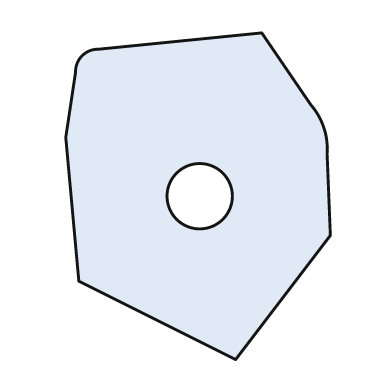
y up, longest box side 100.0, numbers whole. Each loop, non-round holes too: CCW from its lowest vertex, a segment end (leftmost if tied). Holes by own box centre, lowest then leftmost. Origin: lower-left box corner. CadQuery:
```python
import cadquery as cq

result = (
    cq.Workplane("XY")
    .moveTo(52.0, 0.0)
    .lineTo(81.0, 38.0)
    .lineTo(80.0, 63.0)
    .threePointArc((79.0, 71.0), (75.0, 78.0))
    .lineTo(60.0, 100.0)
    .lineTo(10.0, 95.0)
    .threePointArc((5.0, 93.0), (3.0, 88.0))
    .lineTo(0.0, 68.0)
    .lineTo(4.0, 24.0)
    .close()
    .moveTo(41.0, 50.0)
    .circle(10.0)
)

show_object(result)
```